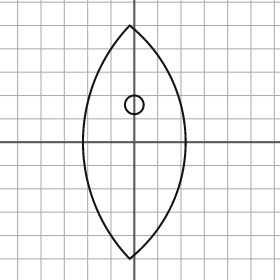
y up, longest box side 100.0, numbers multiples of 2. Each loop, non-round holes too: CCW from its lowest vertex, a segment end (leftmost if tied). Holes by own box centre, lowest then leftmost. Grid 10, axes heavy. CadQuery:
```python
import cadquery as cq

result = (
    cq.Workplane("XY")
    .moveTo(-2.0, -50.0)
    .threePointArc((22.0, 0.0), (-2.0, 50.0))
    .threePointArc((-22.0, 0.0), (-2.0, -50.0))
    .close()
    .moveTo(0.0, 16.0)
    .circle(4.0)
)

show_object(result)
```